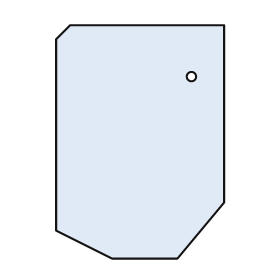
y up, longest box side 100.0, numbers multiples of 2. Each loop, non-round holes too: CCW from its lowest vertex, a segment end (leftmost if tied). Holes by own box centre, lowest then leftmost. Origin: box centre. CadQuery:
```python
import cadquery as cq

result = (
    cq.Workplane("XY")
    .moveTo(-12.0, -50.0)
    .lineTo(16.0, -50.0)
    .lineTo(36.0, -26.0)
    .lineTo(36.0, 50.0)
    .lineTo(-30.0, 50.0)
    .lineTo(-36.0, 44.0)
    .lineTo(-36.0, -38.0)
    .close()
    .moveTo(22.0, 28.0)
    .circle(2.0)
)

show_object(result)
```